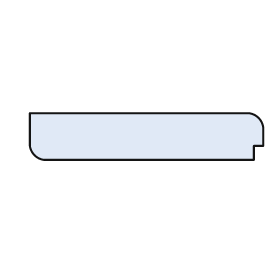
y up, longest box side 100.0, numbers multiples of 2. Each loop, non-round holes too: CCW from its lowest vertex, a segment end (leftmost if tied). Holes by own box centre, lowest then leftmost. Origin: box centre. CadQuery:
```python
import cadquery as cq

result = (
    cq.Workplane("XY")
    .moveTo(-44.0, -10.0)
    .lineTo(46.0, -10.0)
    .lineTo(46.0, -4.0)
    .lineTo(50.0, -4.0)
    .lineTo(50.0, 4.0)
    .threePointArc((48.0, 8.0), (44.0, 10.0))
    .lineTo(-50.0, 10.0)
    .lineTo(-50.0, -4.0)
    .threePointArc((-48.0, -8.0), (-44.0, -10.0))
    .close()
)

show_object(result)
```